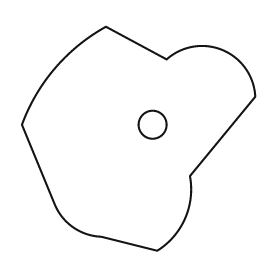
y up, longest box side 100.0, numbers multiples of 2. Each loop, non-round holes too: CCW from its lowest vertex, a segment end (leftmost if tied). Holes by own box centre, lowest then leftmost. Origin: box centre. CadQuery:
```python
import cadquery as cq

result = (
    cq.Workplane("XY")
    .moveTo(8.0, -48.0)
    .threePointArc((20.0, -34.0), (22.0, -16.0))
    .lineTo(50.0, 18.0)
    .threePointArc((36.0, 38.0), (12.0, 34.0))
    .lineTo(-14.0, 48.0)
    .threePointArc((-36.0, 30.0), (-50.0, 6.0))
    .lineTo(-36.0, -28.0)
    .threePointArc((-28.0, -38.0), (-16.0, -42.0))
    .close()
    .moveTo(6.0, 6.0)
    .circle(6.0)
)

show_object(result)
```